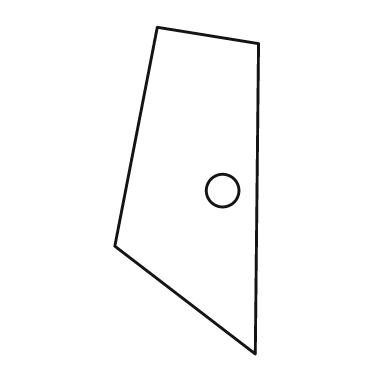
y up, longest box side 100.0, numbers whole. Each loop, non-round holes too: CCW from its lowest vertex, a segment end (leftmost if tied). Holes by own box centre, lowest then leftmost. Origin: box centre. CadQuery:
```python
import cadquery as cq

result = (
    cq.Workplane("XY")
    .moveTo(21.0, -50.0)
    .lineTo(22.0, 45.0)
    .lineTo(-9.0, 50.0)
    .lineTo(-22.0, -17.0)
    .close()
    .moveTo(11.0, 0.0)
    .circle(5.0)
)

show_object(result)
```